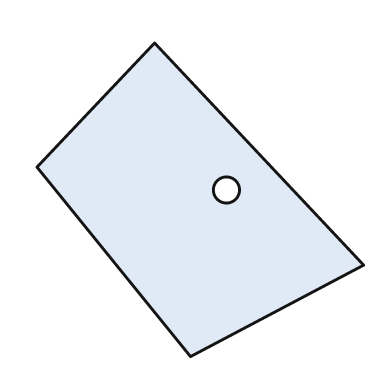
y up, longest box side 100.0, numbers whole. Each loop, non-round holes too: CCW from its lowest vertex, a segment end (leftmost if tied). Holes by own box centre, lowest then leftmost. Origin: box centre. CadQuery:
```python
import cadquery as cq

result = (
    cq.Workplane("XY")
    .moveTo(-3.0, -48.0)
    .lineTo(50.0, -20.0)
    .lineTo(-14.0, 48.0)
    .lineTo(-50.0, 10.0)
    .close()
    .moveTo(8.0, 3.0)
    .circle(4.0)
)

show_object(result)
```